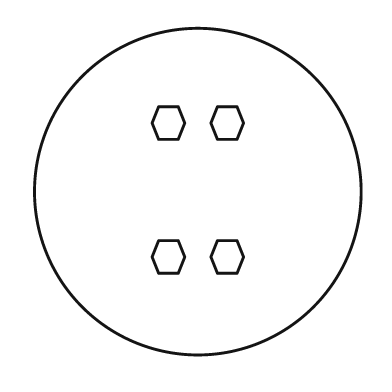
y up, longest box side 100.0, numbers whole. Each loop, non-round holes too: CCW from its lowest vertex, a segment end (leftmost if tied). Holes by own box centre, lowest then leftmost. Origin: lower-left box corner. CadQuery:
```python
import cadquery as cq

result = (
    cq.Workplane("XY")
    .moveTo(50.0, 50.0)
    .circle(50.0)
    .moveTo(38.0, 25.0)
    .lineTo(44.0, 25.0)
    .lineTo(46.0, 30.0)
    .lineTo(44.0, 35.0)
    .lineTo(38.0, 35.0)
    .lineTo(36.0, 30.0)
    .close()
    .moveTo(56.0, 25.0)
    .lineTo(62.0, 25.0)
    .lineTo(64.0, 30.0)
    .lineTo(62.0, 35.0)
    .lineTo(56.0, 35.0)
    .lineTo(54.0, 30.0)
    .close()
    .moveTo(38.0, 66.0)
    .lineTo(44.0, 66.0)
    .lineTo(46.0, 71.0)
    .lineTo(44.0, 76.0)
    .lineTo(38.0, 76.0)
    .lineTo(36.0, 71.0)
    .close()
    .moveTo(56.0, 66.0)
    .lineTo(62.0, 66.0)
    .lineTo(64.0, 71.0)
    .lineTo(62.0, 76.0)
    .lineTo(56.0, 76.0)
    .lineTo(54.0, 71.0)
    .close()
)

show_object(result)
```